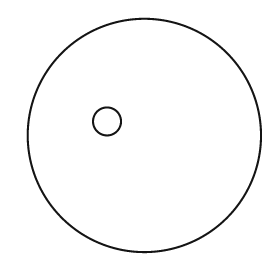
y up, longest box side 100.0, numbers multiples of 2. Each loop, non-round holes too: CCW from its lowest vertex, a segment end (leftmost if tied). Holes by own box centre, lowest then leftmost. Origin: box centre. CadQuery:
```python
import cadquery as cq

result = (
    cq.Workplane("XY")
    .moveTo(0.0, 0.0)
    .circle(50.0)
    .moveTo(-16.0, 6.0)
    .circle(6.0)
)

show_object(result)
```